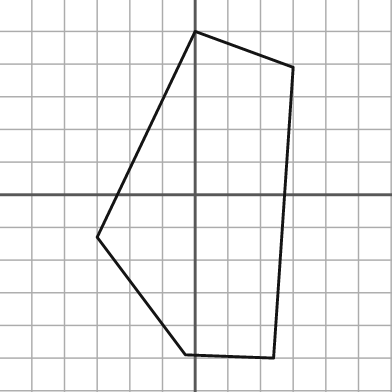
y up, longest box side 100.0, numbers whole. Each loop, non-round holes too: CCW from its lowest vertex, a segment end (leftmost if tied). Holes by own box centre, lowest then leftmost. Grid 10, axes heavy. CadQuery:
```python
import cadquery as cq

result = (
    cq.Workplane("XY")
    .moveTo(24.0, -50.0)
    .lineTo(30.0, 39.0)
    .lineTo(0.0, 50.0)
    .lineTo(-30.0, -13.0)
    .lineTo(-3.0, -49.0)
    .close()
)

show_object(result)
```